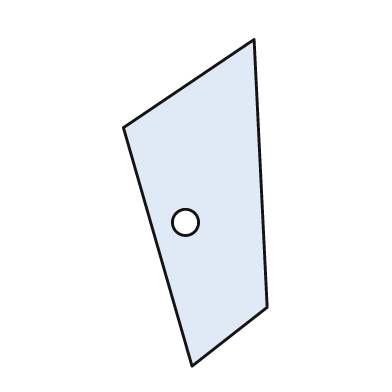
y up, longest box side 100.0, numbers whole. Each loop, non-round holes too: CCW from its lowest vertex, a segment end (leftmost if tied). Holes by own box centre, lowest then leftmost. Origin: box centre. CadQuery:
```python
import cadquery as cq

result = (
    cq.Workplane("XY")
    .moveTo(-1.0, -50.0)
    .lineTo(22.0, -32.0)
    .lineTo(18.0, 50.0)
    .lineTo(-22.0, 23.0)
    .close()
    .moveTo(-3.0, -6.0)
    .circle(4.0)
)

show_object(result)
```